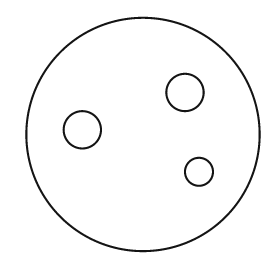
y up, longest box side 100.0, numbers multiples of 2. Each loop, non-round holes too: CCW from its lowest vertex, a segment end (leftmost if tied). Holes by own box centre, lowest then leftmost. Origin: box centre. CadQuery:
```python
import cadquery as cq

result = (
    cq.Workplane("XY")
    .moveTo(0.0, 0.0)
    .circle(50.0)
    .moveTo(24.0, -16.0)
    .circle(6.0)
    .moveTo(-26.0, 2.0)
    .circle(8.0)
    .moveTo(18.0, 18.0)
    .circle(8.0)
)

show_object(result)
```